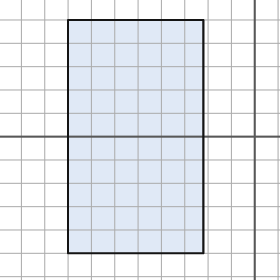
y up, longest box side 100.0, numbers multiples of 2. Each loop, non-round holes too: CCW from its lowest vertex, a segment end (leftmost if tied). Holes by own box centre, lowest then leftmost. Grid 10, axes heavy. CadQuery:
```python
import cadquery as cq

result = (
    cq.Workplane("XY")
    .moveTo(-80.0, -50.0)
    .lineTo(-22.0, -50.0)
    .lineTo(-22.0, 50.0)
    .lineTo(-80.0, 50.0)
    .close()
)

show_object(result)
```